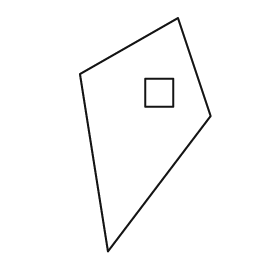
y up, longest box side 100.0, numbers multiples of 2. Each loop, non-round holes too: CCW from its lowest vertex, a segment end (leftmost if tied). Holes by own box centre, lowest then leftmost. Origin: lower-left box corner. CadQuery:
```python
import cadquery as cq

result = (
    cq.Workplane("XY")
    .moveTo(12.0, 0.0)
    .lineTo(56.0, 58.0)
    .lineTo(42.0, 100.0)
    .lineTo(0.0, 76.0)
    .close()
    .moveTo(28.0, 62.0)
    .lineTo(40.0, 62.0)
    .lineTo(40.0, 74.0)
    .lineTo(28.0, 74.0)
    .close()
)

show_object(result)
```